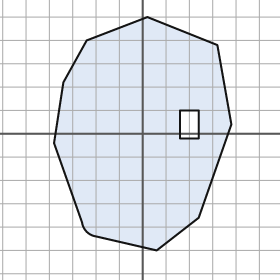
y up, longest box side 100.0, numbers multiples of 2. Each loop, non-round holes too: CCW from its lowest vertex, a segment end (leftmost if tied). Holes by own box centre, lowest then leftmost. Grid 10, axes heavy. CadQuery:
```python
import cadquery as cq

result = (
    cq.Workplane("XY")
    .moveTo(6.0, -50.0)
    .lineTo(24.0, -36.0)
    .lineTo(38.0, 4.0)
    .lineTo(32.0, 38.0)
    .lineTo(2.0, 50.0)
    .lineTo(-24.0, 40.0)
    .lineTo(-34.0, 22.0)
    .lineTo(-38.0, -4.0)
    .lineTo(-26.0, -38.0)
    .threePointArc((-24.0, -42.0), (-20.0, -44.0))
    .close()
    .moveTo(16.0, -2.0)
    .lineTo(24.0, -2.0)
    .lineTo(24.0, 10.0)
    .lineTo(16.0, 10.0)
    .close()
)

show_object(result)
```